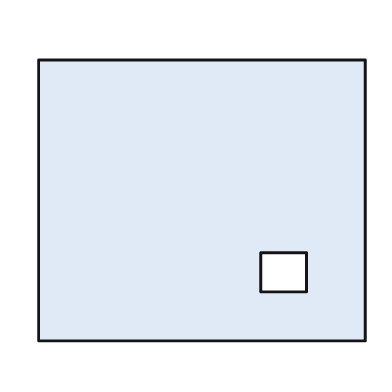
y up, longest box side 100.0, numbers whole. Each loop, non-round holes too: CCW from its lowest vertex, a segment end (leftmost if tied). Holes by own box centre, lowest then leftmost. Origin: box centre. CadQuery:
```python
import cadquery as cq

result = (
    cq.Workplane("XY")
    .moveTo(-50.0, -43.0)
    .lineTo(50.0, -43.0)
    .lineTo(50.0, 43.0)
    .lineTo(-50.0, 43.0)
    .close()
    .moveTo(18.0, -28.0)
    .lineTo(32.0, -28.0)
    .lineTo(32.0, -16.0)
    .lineTo(18.0, -16.0)
    .close()
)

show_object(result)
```